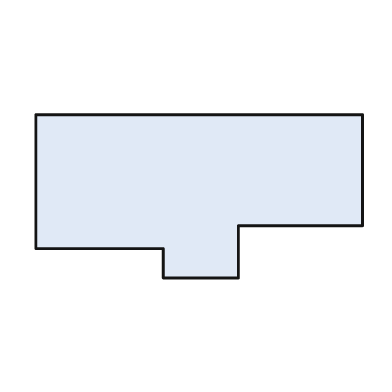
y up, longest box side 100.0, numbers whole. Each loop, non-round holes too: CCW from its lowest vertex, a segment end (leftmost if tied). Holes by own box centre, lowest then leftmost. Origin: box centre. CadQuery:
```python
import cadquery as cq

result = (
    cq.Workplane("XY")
    .moveTo(-11.0, -25.0)
    .lineTo(12.0, -25.0)
    .lineTo(12.0, -9.0)
    .lineTo(50.0, -9.0)
    .lineTo(50.0, 25.0)
    .lineTo(-50.0, 25.0)
    .lineTo(-50.0, -16.0)
    .lineTo(-11.0, -16.0)
    .close()
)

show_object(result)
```